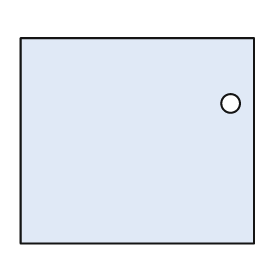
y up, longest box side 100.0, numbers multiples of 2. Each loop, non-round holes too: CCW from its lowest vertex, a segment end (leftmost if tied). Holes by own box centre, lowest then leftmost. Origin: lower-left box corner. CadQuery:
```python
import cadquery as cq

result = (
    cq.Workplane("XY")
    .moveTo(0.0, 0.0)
    .lineTo(100.0, 0.0)
    .lineTo(100.0, 88.0)
    .lineTo(0.0, 88.0)
    .close()
    .moveTo(90.0, 60.0)
    .circle(4.0)
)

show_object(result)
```